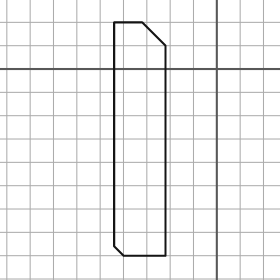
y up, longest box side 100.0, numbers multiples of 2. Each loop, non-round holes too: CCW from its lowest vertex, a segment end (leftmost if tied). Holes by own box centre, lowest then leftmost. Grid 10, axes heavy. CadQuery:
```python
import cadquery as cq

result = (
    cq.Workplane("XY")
    .moveTo(-40.0, -80.0)
    .lineTo(-22.0, -80.0)
    .lineTo(-22.0, 10.0)
    .lineTo(-32.0, 20.0)
    .lineTo(-44.0, 20.0)
    .lineTo(-44.0, -76.0)
    .close()
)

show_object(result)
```